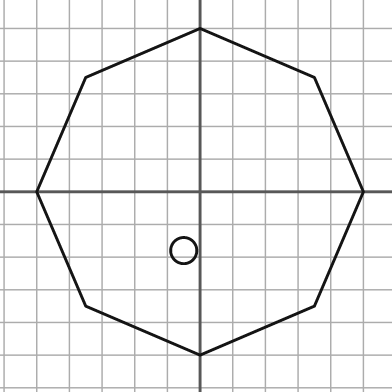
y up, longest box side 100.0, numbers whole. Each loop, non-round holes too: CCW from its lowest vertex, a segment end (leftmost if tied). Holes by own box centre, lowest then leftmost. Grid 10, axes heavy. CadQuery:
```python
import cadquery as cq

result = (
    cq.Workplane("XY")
    .moveTo(0.0, -50.0)
    .lineTo(35.0, -35.0)
    .lineTo(50.0, 0.0)
    .lineTo(35.0, 35.0)
    .lineTo(0.0, 50.0)
    .lineTo(-35.0, 35.0)
    .lineTo(-50.0, 0.0)
    .lineTo(-35.0, -35.0)
    .close()
    .moveTo(-5.0, -18.0)
    .circle(4.0)
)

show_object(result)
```